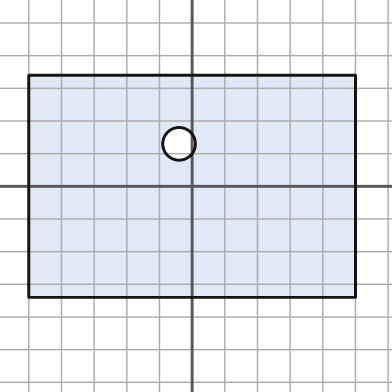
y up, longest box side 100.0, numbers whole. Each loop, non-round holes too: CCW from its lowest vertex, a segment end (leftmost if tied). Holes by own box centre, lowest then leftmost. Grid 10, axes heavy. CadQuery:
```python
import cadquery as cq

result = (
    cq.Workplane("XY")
    .moveTo(-50.0, -34.0)
    .lineTo(50.0, -34.0)
    .lineTo(50.0, 34.0)
    .lineTo(-50.0, 34.0)
    .close()
    .moveTo(-4.0, 13.0)
    .circle(5.0)
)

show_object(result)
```